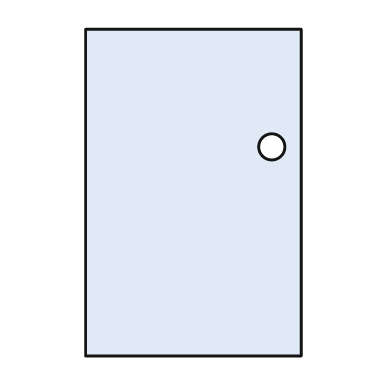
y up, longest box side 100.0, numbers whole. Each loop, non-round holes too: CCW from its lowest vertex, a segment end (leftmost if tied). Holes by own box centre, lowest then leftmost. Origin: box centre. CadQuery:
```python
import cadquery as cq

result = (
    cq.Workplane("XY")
    .moveTo(-33.0, -50.0)
    .lineTo(33.0, -50.0)
    .lineTo(33.0, 50.0)
    .lineTo(-33.0, 50.0)
    .close()
    .moveTo(24.0, 14.0)
    .circle(4.0)
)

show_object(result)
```